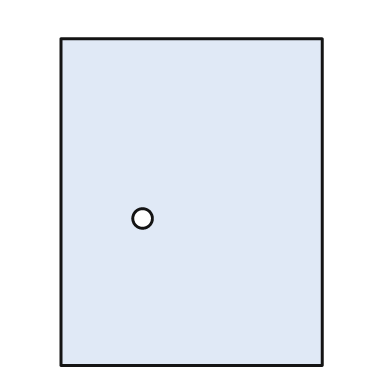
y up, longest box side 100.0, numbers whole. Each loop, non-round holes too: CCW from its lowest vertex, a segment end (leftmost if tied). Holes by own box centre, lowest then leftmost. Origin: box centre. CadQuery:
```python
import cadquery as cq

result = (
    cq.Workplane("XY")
    .moveTo(-40.0, -50.0)
    .lineTo(40.0, -50.0)
    .lineTo(40.0, 50.0)
    .lineTo(-40.0, 50.0)
    .close()
    .moveTo(-15.0, -5.0)
    .circle(3.0)
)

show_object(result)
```